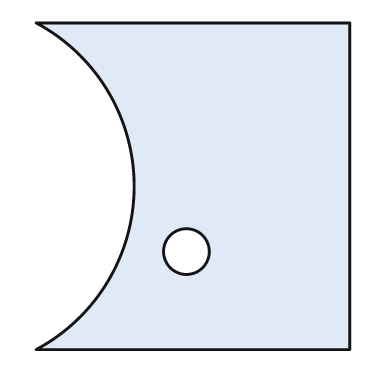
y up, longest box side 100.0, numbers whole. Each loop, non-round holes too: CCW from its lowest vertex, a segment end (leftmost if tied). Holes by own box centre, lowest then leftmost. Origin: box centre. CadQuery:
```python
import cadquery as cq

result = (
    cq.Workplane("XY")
    .moveTo(-48.0, -50.0)
    .lineTo(48.0, -50.0)
    .lineTo(48.0, 50.0)
    .lineTo(-48.0, 50.0)
    .threePointArc((-18.0, 0.0), (-48.0, -50.0))
    .close()
    .moveTo(-2.0, -20.0)
    .circle(7.0)
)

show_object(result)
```